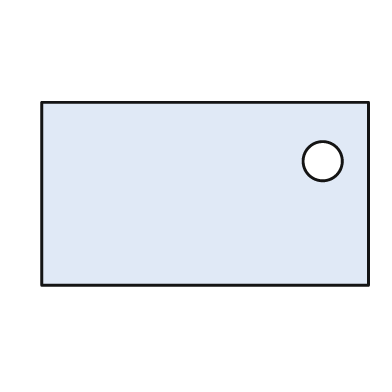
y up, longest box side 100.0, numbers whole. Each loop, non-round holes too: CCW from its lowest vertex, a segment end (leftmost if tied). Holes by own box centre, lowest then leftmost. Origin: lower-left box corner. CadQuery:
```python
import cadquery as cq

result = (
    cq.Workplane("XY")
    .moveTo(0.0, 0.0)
    .lineTo(100.0, 0.0)
    .lineTo(100.0, 56.0)
    .lineTo(0.0, 56.0)
    .close()
    .moveTo(86.0, 38.0)
    .circle(6.0)
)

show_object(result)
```